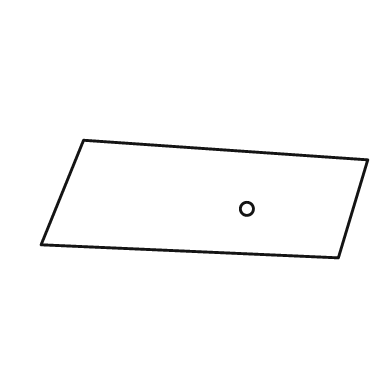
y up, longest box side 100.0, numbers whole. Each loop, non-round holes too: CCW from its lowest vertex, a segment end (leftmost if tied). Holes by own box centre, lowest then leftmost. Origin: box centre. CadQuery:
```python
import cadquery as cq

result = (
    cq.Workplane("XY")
    .moveTo(41.0, -18.0)
    .lineTo(50.0, 12.0)
    .lineTo(-37.0, 18.0)
    .lineTo(-50.0, -14.0)
    .close()
    .moveTo(13.0, -3.0)
    .circle(2.0)
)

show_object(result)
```